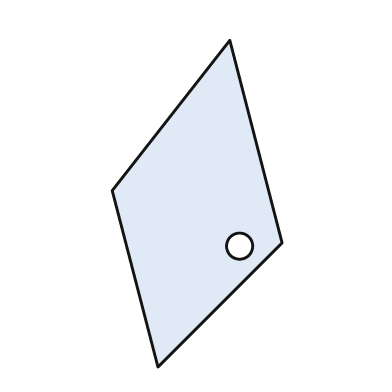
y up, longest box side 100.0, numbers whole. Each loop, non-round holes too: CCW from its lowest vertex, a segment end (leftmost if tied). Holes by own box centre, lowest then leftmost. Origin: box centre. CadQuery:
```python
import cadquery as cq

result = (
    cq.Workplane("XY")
    .moveTo(-12.0, -50.0)
    .lineTo(26.0, -12.0)
    .lineTo(10.0, 50.0)
    .lineTo(-26.0, 4.0)
    .close()
    .moveTo(13.0, -13.0)
    .circle(4.0)
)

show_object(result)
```